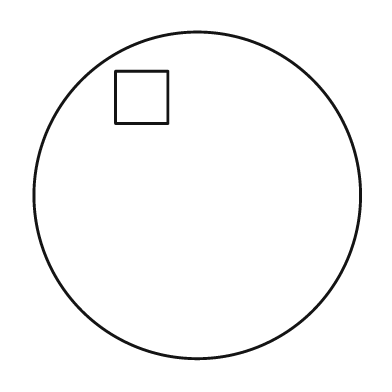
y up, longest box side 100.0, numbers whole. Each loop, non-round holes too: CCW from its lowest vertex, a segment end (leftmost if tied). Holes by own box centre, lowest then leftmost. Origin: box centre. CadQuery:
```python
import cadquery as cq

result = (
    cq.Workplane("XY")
    .moveTo(0.0, 0.0)
    .circle(50.0)
    .moveTo(-25.0, 22.0)
    .lineTo(-9.0, 22.0)
    .lineTo(-9.0, 38.0)
    .lineTo(-25.0, 38.0)
    .close()
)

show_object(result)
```